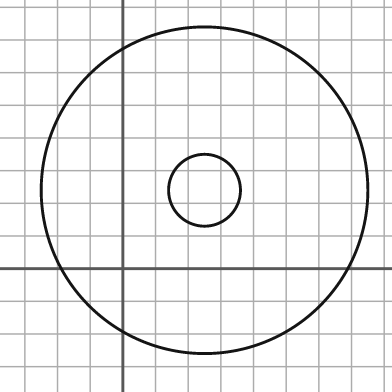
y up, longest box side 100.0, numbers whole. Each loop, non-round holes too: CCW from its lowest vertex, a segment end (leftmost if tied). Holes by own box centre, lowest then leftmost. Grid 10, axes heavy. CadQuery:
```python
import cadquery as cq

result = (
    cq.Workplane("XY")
    .moveTo(25.0, 24.0)
    .circle(50.0)
    .moveTo(25.0, 24.0)
    .circle(11.0)
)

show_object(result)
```